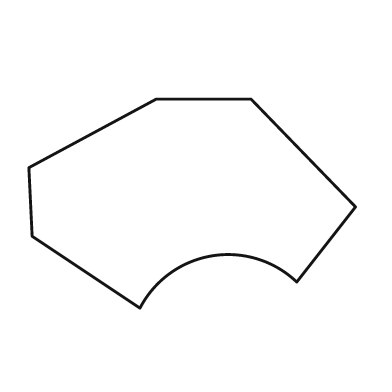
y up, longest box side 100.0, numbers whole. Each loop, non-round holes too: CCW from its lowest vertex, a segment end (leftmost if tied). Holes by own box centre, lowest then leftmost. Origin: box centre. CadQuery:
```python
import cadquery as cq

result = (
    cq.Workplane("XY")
    .moveTo(-16.0, -32.0)
    .threePointArc((6.0, -16.0), (32.0, -24.0))
    .lineTo(50.0, -1.0)
    .lineTo(18.0, 32.0)
    .lineTo(-11.0, 32.0)
    .lineTo(-50.0, 11.0)
    .lineTo(-49.0, -10.0)
    .close()
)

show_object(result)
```